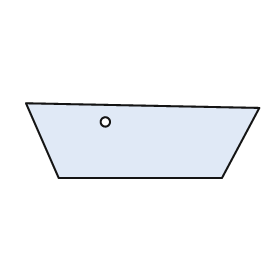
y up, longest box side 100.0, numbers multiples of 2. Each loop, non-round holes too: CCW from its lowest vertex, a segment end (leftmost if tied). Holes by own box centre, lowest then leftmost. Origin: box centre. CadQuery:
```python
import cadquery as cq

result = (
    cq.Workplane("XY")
    .moveTo(-36.0, -16.0)
    .lineTo(34.0, -16.0)
    .lineTo(50.0, 14.0)
    .lineTo(-50.0, 16.0)
    .close()
    .moveTo(-16.0, 8.0)
    .circle(2.0)
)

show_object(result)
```